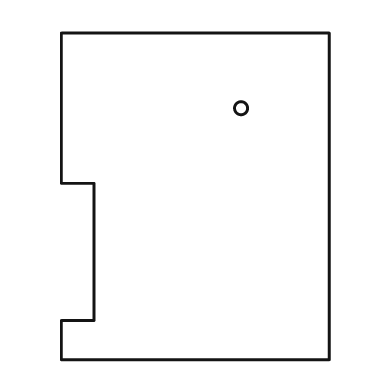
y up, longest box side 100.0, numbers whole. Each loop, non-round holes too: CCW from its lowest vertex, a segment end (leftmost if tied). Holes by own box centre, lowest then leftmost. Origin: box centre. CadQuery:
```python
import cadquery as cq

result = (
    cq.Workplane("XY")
    .moveTo(-41.0, -50.0)
    .lineTo(41.0, -50.0)
    .lineTo(41.0, 50.0)
    .lineTo(-41.0, 50.0)
    .lineTo(-41.0, 4.0)
    .lineTo(-31.0, 4.0)
    .lineTo(-31.0, -38.0)
    .lineTo(-41.0, -38.0)
    .close()
    .moveTo(14.0, 27.0)
    .circle(2.0)
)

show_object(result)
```